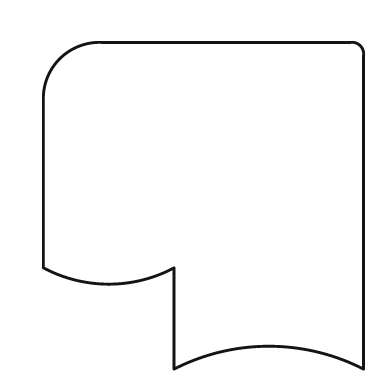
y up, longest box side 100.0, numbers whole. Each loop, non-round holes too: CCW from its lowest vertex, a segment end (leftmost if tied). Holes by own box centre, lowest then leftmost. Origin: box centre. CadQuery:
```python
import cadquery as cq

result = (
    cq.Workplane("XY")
    .moveTo(-9.0, -50.0)
    .threePointArc((20.0, -43.0), (49.0, -50.0))
    .lineTo(49.0, 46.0)
    .threePointArc((48.0, 49.0), (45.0, 50.0))
    .lineTo(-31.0, 50.0)
    .threePointArc((-44.0, 45.0), (-49.0, 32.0))
    .lineTo(-49.0, -19.0)
    .threePointArc((-29.0, -24.0), (-9.0, -19.0))
    .close()
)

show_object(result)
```